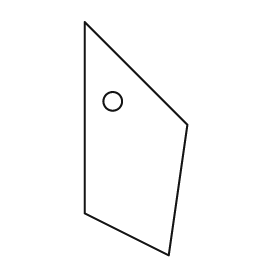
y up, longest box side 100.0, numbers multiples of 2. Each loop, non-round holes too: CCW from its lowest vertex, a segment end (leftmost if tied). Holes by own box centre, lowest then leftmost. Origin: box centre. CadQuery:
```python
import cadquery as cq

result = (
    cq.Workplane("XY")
    .moveTo(14.0, -50.0)
    .lineTo(22.0, 6.0)
    .lineTo(-22.0, 50.0)
    .lineTo(-22.0, -32.0)
    .close()
    .moveTo(-10.0, 16.0)
    .circle(4.0)
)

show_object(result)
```